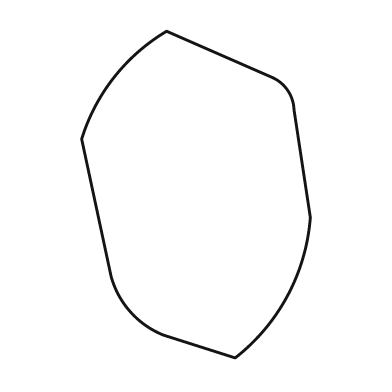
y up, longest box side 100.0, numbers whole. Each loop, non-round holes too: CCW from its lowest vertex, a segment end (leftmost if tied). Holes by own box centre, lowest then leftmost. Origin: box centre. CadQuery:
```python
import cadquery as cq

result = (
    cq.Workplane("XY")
    .moveTo(12.0, -50.0)
    .threePointArc((28.0, -31.0), (35.0, -7.0))
    .lineTo(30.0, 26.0)
    .threePointArc((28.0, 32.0), (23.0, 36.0))
    .lineTo(-9.0, 50.0)
    .threePointArc((-25.0, 36.0), (-35.0, 17.0))
    .lineTo(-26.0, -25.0)
    .threePointArc((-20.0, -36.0), (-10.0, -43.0))
    .close()
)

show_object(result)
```